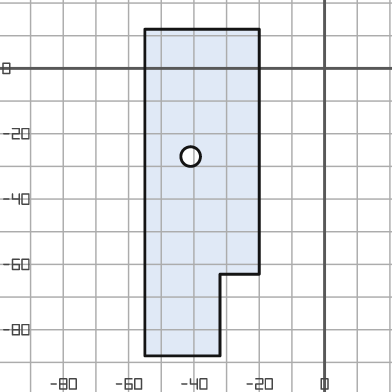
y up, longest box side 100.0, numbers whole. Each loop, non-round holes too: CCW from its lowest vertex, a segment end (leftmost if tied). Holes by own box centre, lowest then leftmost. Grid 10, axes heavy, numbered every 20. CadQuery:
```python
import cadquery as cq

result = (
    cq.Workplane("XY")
    .moveTo(-55.0, -88.0)
    .lineTo(-32.0, -88.0)
    .lineTo(-32.0, -63.0)
    .lineTo(-20.0, -63.0)
    .lineTo(-20.0, 12.0)
    .lineTo(-55.0, 12.0)
    .close()
    .moveTo(-41.0, -27.0)
    .circle(3.0)
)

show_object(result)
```